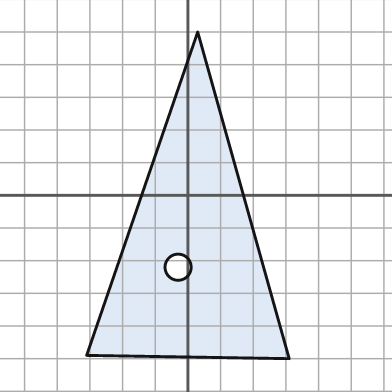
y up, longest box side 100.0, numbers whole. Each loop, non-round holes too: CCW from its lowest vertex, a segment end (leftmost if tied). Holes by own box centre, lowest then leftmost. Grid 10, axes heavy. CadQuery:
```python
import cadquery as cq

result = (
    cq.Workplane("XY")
    .moveTo(31.0, -50.0)
    .lineTo(3.0, 50.0)
    .lineTo(-31.0, -49.0)
    .close()
    .moveTo(-3.0, -22.0)
    .circle(4.0)
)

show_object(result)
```